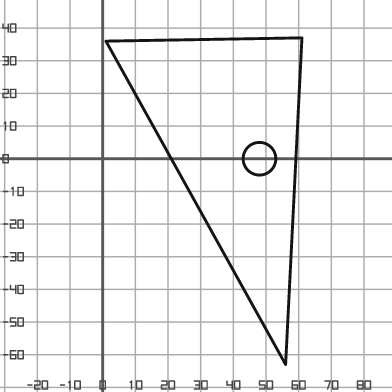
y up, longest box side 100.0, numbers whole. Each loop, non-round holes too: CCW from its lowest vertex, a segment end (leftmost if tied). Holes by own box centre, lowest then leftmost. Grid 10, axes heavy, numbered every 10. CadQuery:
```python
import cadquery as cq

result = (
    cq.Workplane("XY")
    .moveTo(56.0, -63.0)
    .lineTo(61.0, 37.0)
    .lineTo(1.0, 36.0)
    .close()
    .moveTo(48.0, 0.0)
    .circle(5.0)
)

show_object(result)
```